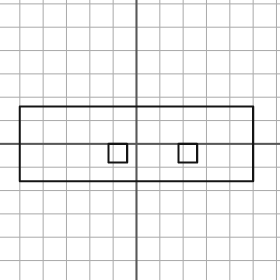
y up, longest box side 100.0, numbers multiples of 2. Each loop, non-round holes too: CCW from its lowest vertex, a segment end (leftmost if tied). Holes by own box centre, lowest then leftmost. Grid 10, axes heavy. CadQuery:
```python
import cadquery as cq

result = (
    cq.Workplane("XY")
    .moveTo(-50.0, -16.0)
    .lineTo(50.0, -16.0)
    .lineTo(50.0, 16.0)
    .lineTo(-50.0, 16.0)
    .close()
    .moveTo(-12.0, -8.0)
    .lineTo(-4.0, -8.0)
    .lineTo(-4.0, 0.0)
    .lineTo(-12.0, 0.0)
    .close()
    .moveTo(18.0, -8.0)
    .lineTo(26.0, -8.0)
    .lineTo(26.0, 0.0)
    .lineTo(18.0, 0.0)
    .close()
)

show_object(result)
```